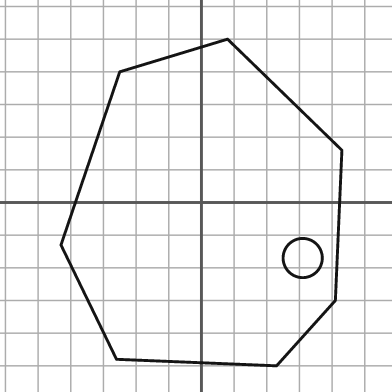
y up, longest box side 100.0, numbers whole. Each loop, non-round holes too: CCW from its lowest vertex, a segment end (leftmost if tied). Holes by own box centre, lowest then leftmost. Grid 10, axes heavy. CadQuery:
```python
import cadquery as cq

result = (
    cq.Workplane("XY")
    .moveTo(23.0, -50.0)
    .lineTo(41.0, -30.0)
    .lineTo(43.0, 16.0)
    .lineTo(8.0, 50.0)
    .lineTo(-25.0, 40.0)
    .lineTo(-43.0, -13.0)
    .lineTo(-26.0, -48.0)
    .close()
    .moveTo(31.0, -17.0)
    .circle(6.0)
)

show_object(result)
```